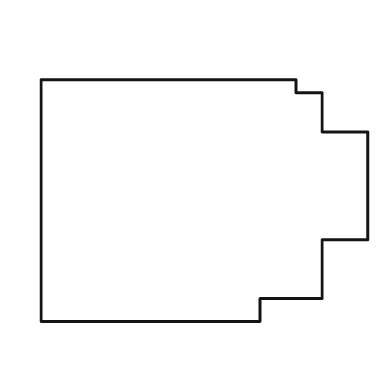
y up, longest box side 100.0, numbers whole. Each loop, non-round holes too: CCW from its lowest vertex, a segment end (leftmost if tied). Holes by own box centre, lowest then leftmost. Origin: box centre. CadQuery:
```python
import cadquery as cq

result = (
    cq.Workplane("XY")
    .moveTo(-50.0, -37.0)
    .lineTo(17.0, -37.0)
    .lineTo(17.0, -30.0)
    .lineTo(36.0, -30.0)
    .lineTo(36.0, -12.0)
    .lineTo(50.0, -12.0)
    .lineTo(50.0, 21.0)
    .lineTo(36.0, 21.0)
    .lineTo(36.0, 33.0)
    .lineTo(28.0, 33.0)
    .lineTo(28.0, 37.0)
    .lineTo(-50.0, 37.0)
    .close()
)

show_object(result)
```